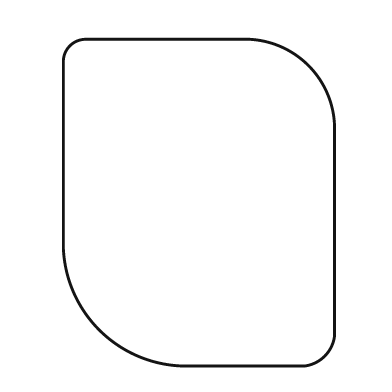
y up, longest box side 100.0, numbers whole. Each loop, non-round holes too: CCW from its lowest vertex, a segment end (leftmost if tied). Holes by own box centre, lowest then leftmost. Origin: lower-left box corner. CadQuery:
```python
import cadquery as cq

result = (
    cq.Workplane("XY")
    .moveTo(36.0, 0.0)
    .lineTo(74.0, 0.0)
    .threePointArc((80.0, 3.0), (83.0, 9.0))
    .lineTo(83.0, 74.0)
    .threePointArc((75.0, 92.0), (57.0, 100.0))
    .lineTo(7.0, 100.0)
    .threePointArc((2.0, 98.0), (0.0, 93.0))
    .lineTo(0.0, 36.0)
    .threePointArc((11.0, 11.0), (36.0, 0.0))
    .close()
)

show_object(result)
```